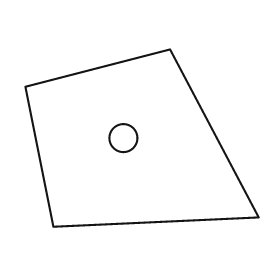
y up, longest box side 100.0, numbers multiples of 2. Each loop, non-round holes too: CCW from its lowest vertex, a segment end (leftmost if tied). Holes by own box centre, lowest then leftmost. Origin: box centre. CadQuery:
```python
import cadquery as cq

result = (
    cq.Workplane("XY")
    .moveTo(-38.0, -38.0)
    .lineTo(50.0, -34.0)
    .lineTo(12.0, 38.0)
    .lineTo(-50.0, 22.0)
    .close()
    .moveTo(-8.0, 0.0)
    .circle(6.0)
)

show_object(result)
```